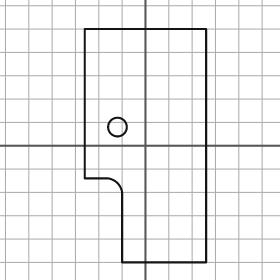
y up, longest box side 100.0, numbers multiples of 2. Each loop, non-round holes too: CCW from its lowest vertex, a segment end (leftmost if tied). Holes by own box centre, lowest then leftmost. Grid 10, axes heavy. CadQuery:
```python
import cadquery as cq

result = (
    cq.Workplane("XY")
    .moveTo(-10.0, -50.0)
    .lineTo(26.0, -50.0)
    .lineTo(26.0, 50.0)
    .lineTo(-26.0, 50.0)
    .lineTo(-26.0, -14.0)
    .lineTo(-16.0, -14.0)
    .threePointArc((-12.0, -16.0), (-10.0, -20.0))
    .close()
    .moveTo(-12.0, 8.0)
    .circle(4.0)
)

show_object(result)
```